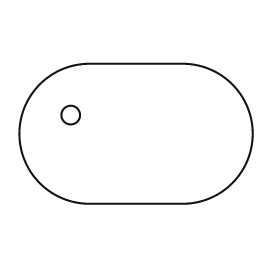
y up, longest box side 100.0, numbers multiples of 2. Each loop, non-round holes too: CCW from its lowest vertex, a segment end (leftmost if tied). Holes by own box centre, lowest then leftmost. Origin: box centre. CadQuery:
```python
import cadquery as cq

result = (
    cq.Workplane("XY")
    .moveTo(-20.0, -30.0)
    .lineTo(20.0, -30.0)
    .threePointArc((50.0, 0.0), (20.0, 30.0))
    .lineTo(-20.0, 30.0)
    .threePointArc((-50.0, 0.0), (-20.0, -30.0))
    .close()
    .moveTo(-28.0, 8.0)
    .circle(4.0)
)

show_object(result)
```